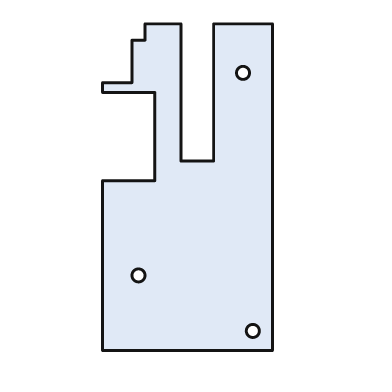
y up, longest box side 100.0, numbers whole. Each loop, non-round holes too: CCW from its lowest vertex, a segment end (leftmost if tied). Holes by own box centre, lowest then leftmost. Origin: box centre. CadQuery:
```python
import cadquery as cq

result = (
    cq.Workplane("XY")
    .moveTo(-26.0, -50.0)
    .lineTo(26.0, -50.0)
    .lineTo(26.0, 50.0)
    .lineTo(8.0, 50.0)
    .lineTo(8.0, 8.0)
    .lineTo(-2.0, 8.0)
    .lineTo(-2.0, 50.0)
    .lineTo(-13.0, 50.0)
    .lineTo(-13.0, 45.0)
    .lineTo(-17.0, 45.0)
    .lineTo(-17.0, 32.0)
    .lineTo(-26.0, 32.0)
    .lineTo(-26.0, 29.0)
    .lineTo(-10.0, 29.0)
    .lineTo(-10.0, 2.0)
    .lineTo(-26.0, 2.0)
    .close()
    .moveTo(20.0, -44.0)
    .circle(2.0)
    .moveTo(-15.0, -27.0)
    .circle(2.0)
    .moveTo(17.0, 35.0)
    .circle(2.0)
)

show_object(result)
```